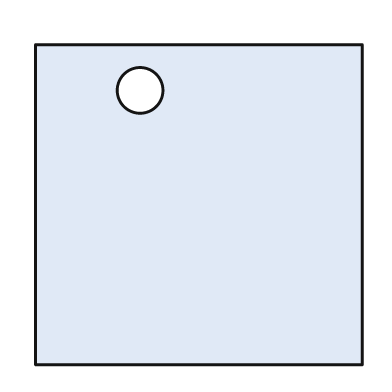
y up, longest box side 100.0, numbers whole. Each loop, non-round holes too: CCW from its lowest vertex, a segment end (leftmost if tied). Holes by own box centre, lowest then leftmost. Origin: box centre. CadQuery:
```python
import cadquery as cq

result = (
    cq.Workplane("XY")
    .moveTo(-50.0, -49.0)
    .lineTo(50.0, -49.0)
    .lineTo(50.0, 49.0)
    .lineTo(-50.0, 49.0)
    .close()
    .moveTo(-18.0, 35.0)
    .circle(7.0)
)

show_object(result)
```